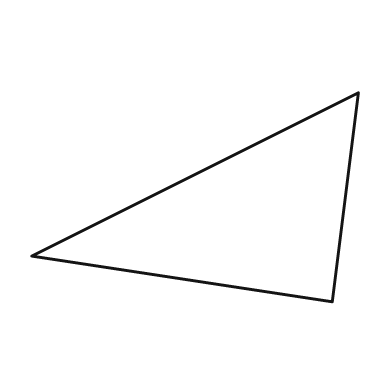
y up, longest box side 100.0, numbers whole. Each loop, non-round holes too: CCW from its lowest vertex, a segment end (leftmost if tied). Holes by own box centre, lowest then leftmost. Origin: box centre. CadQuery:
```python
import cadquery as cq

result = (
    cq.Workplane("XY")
    .moveTo(42.0, -32.0)
    .lineTo(50.0, 32.0)
    .lineTo(-50.0, -18.0)
    .close()
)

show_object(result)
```